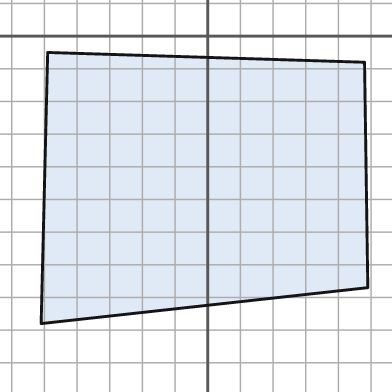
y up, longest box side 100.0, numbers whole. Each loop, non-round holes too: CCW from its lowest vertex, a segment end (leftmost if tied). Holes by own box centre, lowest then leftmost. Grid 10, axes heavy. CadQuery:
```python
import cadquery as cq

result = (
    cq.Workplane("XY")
    .moveTo(-51.0, -88.0)
    .lineTo(49.0, -77.0)
    .lineTo(48.0, -8.0)
    .lineTo(-49.0, -5.0)
    .close()
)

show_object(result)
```